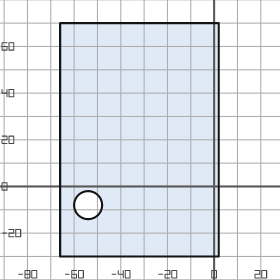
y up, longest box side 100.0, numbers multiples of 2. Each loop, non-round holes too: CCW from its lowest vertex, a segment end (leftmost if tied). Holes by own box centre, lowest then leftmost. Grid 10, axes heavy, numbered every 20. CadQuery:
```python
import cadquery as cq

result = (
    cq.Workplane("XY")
    .moveTo(-66.0, -30.0)
    .lineTo(2.0, -30.0)
    .lineTo(2.0, 70.0)
    .lineTo(-66.0, 70.0)
    .close()
    .moveTo(-54.0, -8.0)
    .circle(6.0)
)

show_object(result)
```